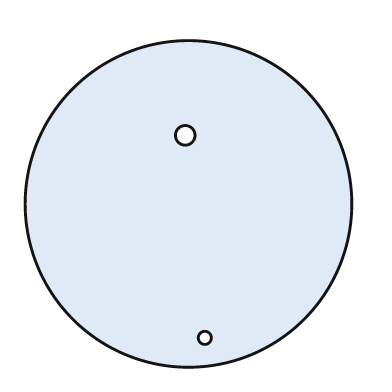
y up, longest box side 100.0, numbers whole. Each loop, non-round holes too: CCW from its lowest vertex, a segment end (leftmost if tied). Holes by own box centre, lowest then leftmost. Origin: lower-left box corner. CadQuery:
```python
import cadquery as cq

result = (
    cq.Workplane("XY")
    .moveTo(50.0, 50.0)
    .circle(50.0)
    .moveTo(55.0, 9.0)
    .circle(2.0)
    .moveTo(49.0, 71.0)
    .circle(3.0)
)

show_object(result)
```